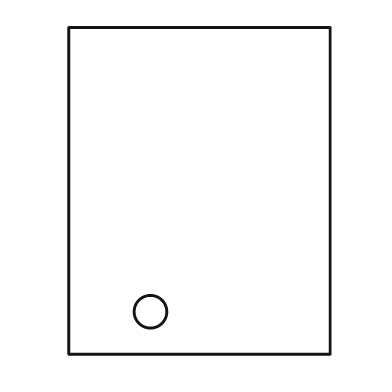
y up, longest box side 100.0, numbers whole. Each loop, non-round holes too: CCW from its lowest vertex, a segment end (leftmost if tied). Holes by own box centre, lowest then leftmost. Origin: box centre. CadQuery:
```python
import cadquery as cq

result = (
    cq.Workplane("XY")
    .moveTo(-40.0, -50.0)
    .lineTo(40.0, -50.0)
    .lineTo(40.0, 50.0)
    .lineTo(-40.0, 50.0)
    .close()
    .moveTo(-15.0, -37.0)
    .circle(5.0)
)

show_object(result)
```